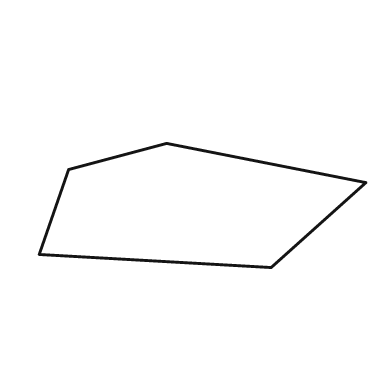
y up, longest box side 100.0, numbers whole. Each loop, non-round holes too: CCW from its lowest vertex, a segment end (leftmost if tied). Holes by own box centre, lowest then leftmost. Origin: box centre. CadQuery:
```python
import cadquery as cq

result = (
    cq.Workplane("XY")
    .moveTo(21.0, -19.0)
    .lineTo(50.0, 7.0)
    .lineTo(-11.0, 19.0)
    .lineTo(-41.0, 11.0)
    .lineTo(-50.0, -15.0)
    .close()
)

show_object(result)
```